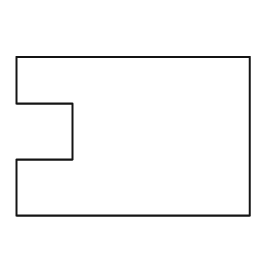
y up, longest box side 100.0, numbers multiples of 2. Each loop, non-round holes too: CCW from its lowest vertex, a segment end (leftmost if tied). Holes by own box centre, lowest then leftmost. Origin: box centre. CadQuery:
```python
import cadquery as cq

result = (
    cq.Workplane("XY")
    .moveTo(-50.0, -34.0)
    .lineTo(50.0, -34.0)
    .lineTo(50.0, 34.0)
    .lineTo(-50.0, 34.0)
    .lineTo(-50.0, 14.0)
    .lineTo(-26.0, 14.0)
    .lineTo(-26.0, -10.0)
    .lineTo(-50.0, -10.0)
    .close()
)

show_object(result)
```